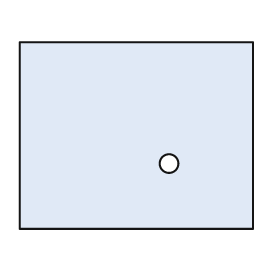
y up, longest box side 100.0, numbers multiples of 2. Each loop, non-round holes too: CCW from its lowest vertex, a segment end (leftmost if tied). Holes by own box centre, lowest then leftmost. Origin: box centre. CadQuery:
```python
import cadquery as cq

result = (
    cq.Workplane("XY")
    .moveTo(-50.0, -40.0)
    .lineTo(50.0, -40.0)
    .lineTo(50.0, 40.0)
    .lineTo(-50.0, 40.0)
    .close()
    .moveTo(14.0, -12.0)
    .circle(4.0)
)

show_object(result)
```